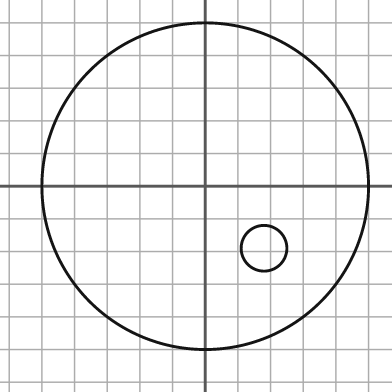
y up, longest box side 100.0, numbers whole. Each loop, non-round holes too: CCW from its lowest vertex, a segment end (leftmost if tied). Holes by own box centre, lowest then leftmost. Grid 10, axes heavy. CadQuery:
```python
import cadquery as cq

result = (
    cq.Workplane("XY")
    .moveTo(0.0, 0.0)
    .circle(50.0)
    .moveTo(18.0, -19.0)
    .circle(7.0)
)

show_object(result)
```